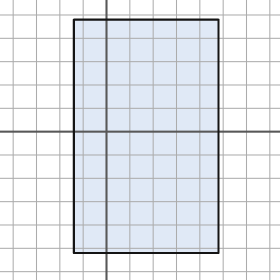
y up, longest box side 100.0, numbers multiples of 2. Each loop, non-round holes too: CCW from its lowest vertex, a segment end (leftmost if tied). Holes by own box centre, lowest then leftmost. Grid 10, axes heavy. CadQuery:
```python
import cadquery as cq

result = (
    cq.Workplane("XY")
    .moveTo(-14.0, -52.0)
    .lineTo(48.0, -52.0)
    .lineTo(48.0, 48.0)
    .lineTo(-14.0, 48.0)
    .close()
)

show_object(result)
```